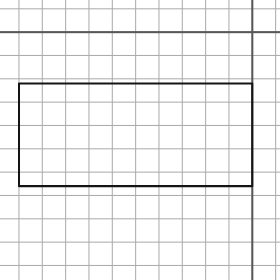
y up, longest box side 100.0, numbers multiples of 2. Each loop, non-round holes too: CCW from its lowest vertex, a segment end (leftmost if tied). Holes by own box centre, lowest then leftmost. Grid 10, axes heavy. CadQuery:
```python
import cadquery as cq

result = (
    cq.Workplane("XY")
    .moveTo(-100.0, -66.0)
    .lineTo(0.0, -66.0)
    .lineTo(0.0, -22.0)
    .lineTo(-100.0, -22.0)
    .close()
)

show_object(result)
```